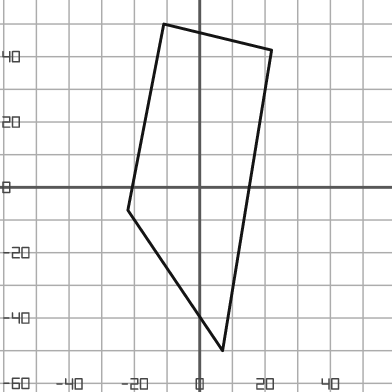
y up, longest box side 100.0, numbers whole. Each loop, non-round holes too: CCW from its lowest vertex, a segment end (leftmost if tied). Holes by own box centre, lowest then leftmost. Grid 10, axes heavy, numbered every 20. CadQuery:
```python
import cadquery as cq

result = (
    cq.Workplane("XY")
    .moveTo(7.0, -50.0)
    .lineTo(22.0, 42.0)
    .lineTo(-11.0, 50.0)
    .lineTo(-22.0, -7.0)
    .close()
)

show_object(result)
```